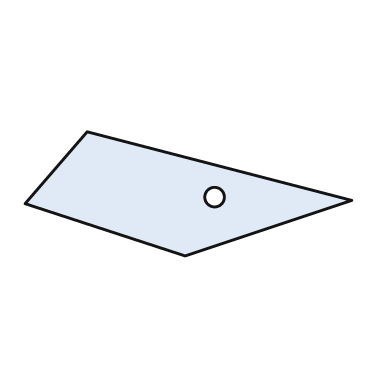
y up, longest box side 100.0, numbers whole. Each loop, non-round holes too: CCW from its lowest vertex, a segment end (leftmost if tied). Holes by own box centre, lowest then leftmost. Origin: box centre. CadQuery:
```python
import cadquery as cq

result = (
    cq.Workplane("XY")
    .moveTo(-1.0, -19.0)
    .lineTo(50.0, -2.0)
    .lineTo(-31.0, 19.0)
    .lineTo(-50.0, -3.0)
    .close()
    .moveTo(8.0, -1.0)
    .circle(3.0)
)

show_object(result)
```